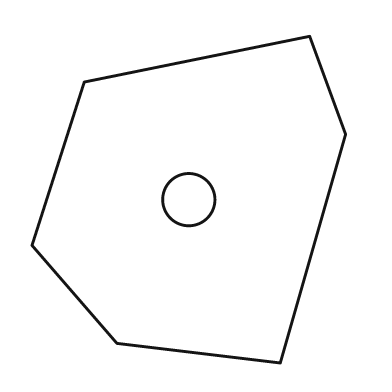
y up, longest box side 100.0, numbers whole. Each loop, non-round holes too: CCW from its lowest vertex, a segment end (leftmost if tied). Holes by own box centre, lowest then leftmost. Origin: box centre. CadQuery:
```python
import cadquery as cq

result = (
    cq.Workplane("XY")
    .moveTo(28.0, -50.0)
    .lineTo(48.0, 20.0)
    .lineTo(37.0, 50.0)
    .lineTo(-32.0, 36.0)
    .lineTo(-48.0, -14.0)
    .lineTo(-22.0, -44.0)
    .close()
    .moveTo(0.0, 0.0)
    .circle(8.0)
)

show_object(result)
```